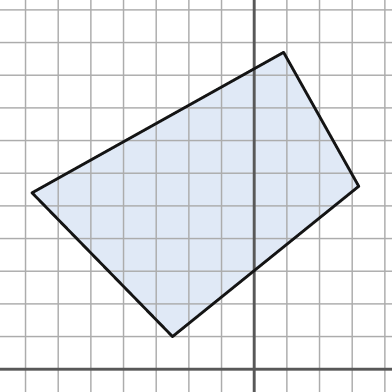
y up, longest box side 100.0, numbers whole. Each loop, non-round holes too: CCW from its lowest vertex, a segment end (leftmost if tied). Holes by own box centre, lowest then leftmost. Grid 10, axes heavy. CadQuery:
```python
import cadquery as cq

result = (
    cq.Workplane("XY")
    .moveTo(-25.0, 10.0)
    .lineTo(32.0, 56.0)
    .lineTo(9.0, 97.0)
    .lineTo(-68.0, 54.0)
    .close()
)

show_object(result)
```